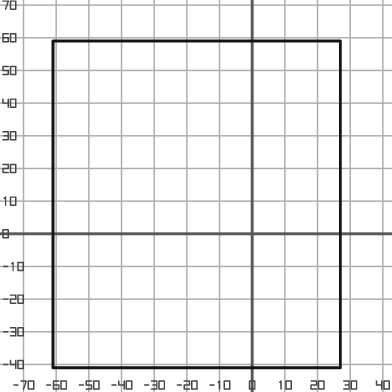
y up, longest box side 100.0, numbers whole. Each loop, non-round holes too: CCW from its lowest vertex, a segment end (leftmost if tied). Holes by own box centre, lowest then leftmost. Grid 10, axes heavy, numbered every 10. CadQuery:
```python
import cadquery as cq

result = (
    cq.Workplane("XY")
    .moveTo(-61.0, -41.0)
    .lineTo(27.0, -41.0)
    .lineTo(27.0, 59.0)
    .lineTo(-61.0, 59.0)
    .close()
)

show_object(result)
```